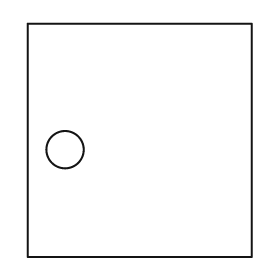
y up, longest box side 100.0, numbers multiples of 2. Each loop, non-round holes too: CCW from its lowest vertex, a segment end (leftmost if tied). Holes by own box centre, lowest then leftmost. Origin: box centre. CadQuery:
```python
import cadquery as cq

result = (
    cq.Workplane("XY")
    .moveTo(-48.0, -50.0)
    .lineTo(48.0, -50.0)
    .lineTo(48.0, 50.0)
    .lineTo(-48.0, 50.0)
    .close()
    .moveTo(-32.0, -4.0)
    .circle(8.0)
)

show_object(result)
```